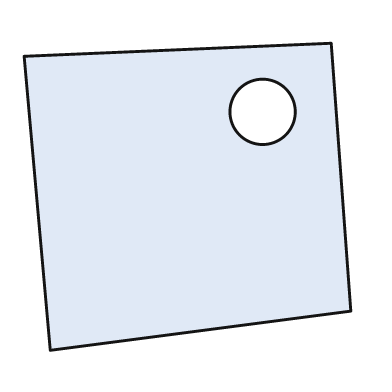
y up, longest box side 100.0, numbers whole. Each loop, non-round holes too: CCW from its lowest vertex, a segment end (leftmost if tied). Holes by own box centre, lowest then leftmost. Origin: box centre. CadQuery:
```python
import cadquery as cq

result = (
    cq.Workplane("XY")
    .moveTo(-42.0, -47.0)
    .lineTo(50.0, -35.0)
    .lineTo(44.0, 47.0)
    .lineTo(-50.0, 43.0)
    .close()
    .moveTo(23.0, 26.0)
    .circle(10.0)
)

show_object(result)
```